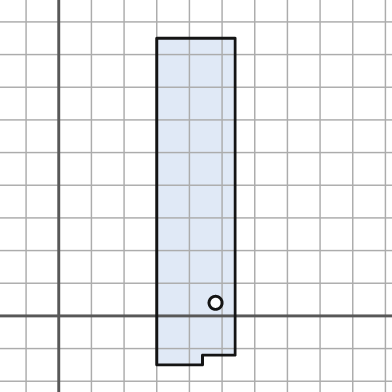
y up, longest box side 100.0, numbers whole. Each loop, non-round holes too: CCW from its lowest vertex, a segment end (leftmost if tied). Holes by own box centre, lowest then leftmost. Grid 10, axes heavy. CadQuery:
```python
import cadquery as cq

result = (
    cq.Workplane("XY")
    .moveTo(30.0, -15.0)
    .lineTo(44.0, -15.0)
    .lineTo(44.0, -12.0)
    .lineTo(54.0, -12.0)
    .lineTo(54.0, 85.0)
    .lineTo(30.0, 85.0)
    .close()
    .moveTo(48.0, 4.0)
    .circle(2.0)
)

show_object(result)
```